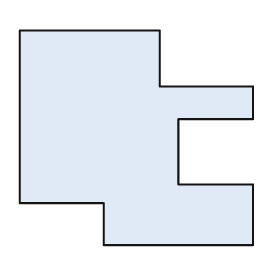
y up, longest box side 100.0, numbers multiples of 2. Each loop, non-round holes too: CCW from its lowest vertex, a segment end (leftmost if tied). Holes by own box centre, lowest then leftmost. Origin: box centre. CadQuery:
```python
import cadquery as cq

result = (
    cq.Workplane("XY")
    .moveTo(-14.0, -46.0)
    .lineTo(50.0, -46.0)
    .lineTo(50.0, -20.0)
    .lineTo(18.0, -20.0)
    .lineTo(18.0, 8.0)
    .lineTo(50.0, 8.0)
    .lineTo(50.0, 22.0)
    .lineTo(10.0, 22.0)
    .lineTo(10.0, 46.0)
    .lineTo(-50.0, 46.0)
    .lineTo(-50.0, -28.0)
    .lineTo(-14.0, -28.0)
    .close()
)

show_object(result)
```